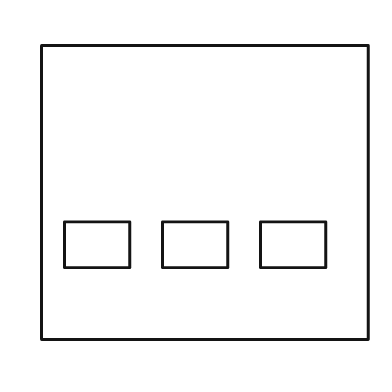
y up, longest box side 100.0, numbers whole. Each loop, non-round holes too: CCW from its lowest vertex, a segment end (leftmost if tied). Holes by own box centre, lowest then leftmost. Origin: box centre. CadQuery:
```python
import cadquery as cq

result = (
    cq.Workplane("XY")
    .moveTo(-50.0, -45.0)
    .lineTo(50.0, -45.0)
    .lineTo(50.0, 45.0)
    .lineTo(-50.0, 45.0)
    .close()
    .moveTo(-43.0, -23.0)
    .lineTo(-23.0, -23.0)
    .lineTo(-23.0, -9.0)
    .lineTo(-43.0, -9.0)
    .close()
    .moveTo(-13.0, -23.0)
    .lineTo(7.0, -23.0)
    .lineTo(7.0, -9.0)
    .lineTo(-13.0, -9.0)
    .close()
    .moveTo(17.0, -23.0)
    .lineTo(37.0, -23.0)
    .lineTo(37.0, -9.0)
    .lineTo(17.0, -9.0)
    .close()
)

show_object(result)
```